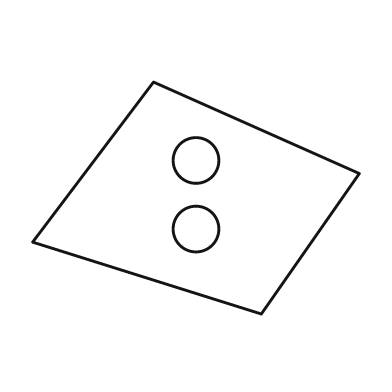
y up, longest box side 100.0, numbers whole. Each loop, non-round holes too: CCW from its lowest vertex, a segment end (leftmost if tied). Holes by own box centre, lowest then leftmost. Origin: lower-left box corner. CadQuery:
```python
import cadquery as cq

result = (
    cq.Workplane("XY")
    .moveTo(70.0, 0.0)
    .lineTo(100.0, 43.0)
    .lineTo(37.0, 71.0)
    .lineTo(0.0, 22.0)
    .close()
    .moveTo(50.0, 26.0)
    .circle(7.0)
    .moveTo(50.0, 47.0)
    .circle(7.0)
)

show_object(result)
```